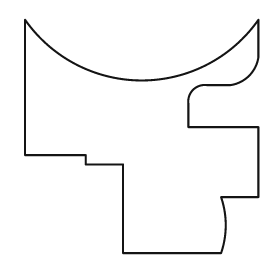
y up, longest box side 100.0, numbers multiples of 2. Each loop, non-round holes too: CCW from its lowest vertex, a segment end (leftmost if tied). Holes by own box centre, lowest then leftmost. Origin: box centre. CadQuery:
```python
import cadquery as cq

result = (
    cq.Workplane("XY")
    .moveTo(-8.0, -50.0)
    .lineTo(34.0, -50.0)
    .threePointArc((36.0, -38.0), (34.0, -26.0))
    .lineTo(50.0, -26.0)
    .lineTo(50.0, 4.0)
    .lineTo(20.0, 4.0)
    .lineTo(20.0, 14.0)
    .threePointArc((22.0, 20.0), (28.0, 22.0))
    .lineTo(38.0, 22.0)
    .threePointArc((46.0, 26.0), (50.0, 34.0))
    .lineTo(50.0, 50.0)
    .threePointArc((0.0, 24.0), (-50.0, 50.0))
    .lineTo(-50.0, -8.0)
    .lineTo(-24.0, -8.0)
    .lineTo(-24.0, -12.0)
    .lineTo(-8.0, -12.0)
    .close()
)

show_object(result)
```